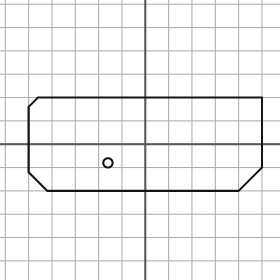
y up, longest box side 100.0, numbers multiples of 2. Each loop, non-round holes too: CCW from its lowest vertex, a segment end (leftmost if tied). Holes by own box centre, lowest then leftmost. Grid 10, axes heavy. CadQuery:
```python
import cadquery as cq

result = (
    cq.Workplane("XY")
    .moveTo(-42.0, -20.0)
    .lineTo(40.0, -20.0)
    .lineTo(50.0, -10.0)
    .lineTo(50.0, 20.0)
    .lineTo(-46.0, 20.0)
    .lineTo(-50.0, 16.0)
    .lineTo(-50.0, -12.0)
    .close()
    .moveTo(-16.0, -8.0)
    .circle(2.0)
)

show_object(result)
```